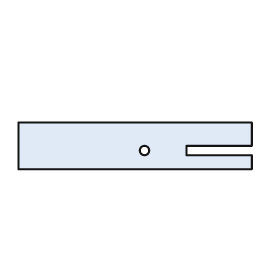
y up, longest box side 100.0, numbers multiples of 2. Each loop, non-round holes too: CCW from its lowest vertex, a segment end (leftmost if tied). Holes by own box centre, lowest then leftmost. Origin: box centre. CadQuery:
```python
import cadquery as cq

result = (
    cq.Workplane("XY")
    .moveTo(-50.0, -10.0)
    .lineTo(50.0, -10.0)
    .lineTo(50.0, -4.0)
    .lineTo(22.0, -4.0)
    .lineTo(22.0, 0.0)
    .lineTo(50.0, 0.0)
    .lineTo(50.0, 10.0)
    .lineTo(-50.0, 10.0)
    .close()
    .moveTo(4.0, -2.0)
    .circle(2.0)
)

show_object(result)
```